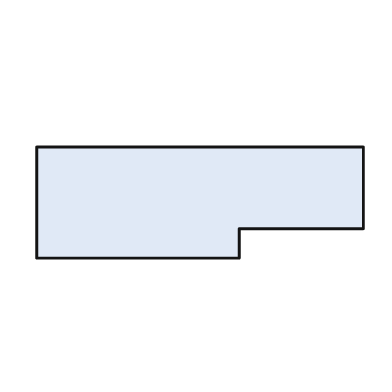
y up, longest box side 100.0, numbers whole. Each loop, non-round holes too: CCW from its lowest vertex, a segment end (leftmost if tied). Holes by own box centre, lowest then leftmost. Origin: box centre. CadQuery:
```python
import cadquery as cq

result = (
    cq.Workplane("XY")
    .moveTo(-50.0, -17.0)
    .lineTo(12.0, -17.0)
    .lineTo(12.0, -8.0)
    .lineTo(50.0, -8.0)
    .lineTo(50.0, 17.0)
    .lineTo(-50.0, 17.0)
    .close()
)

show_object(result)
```